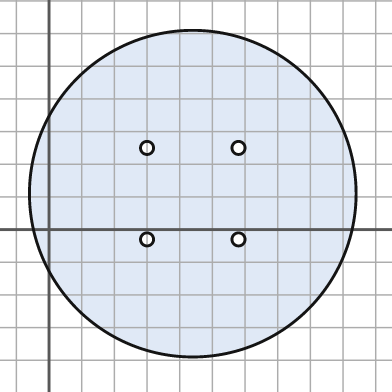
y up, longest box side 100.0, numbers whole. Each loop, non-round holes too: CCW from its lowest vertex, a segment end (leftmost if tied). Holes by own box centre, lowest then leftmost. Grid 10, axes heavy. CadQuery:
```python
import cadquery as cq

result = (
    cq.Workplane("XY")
    .moveTo(44.0, 11.0)
    .circle(50.0)
    .moveTo(30.0, -3.0)
    .circle(2.0)
    .moveTo(58.0, -3.0)
    .circle(2.0)
    .moveTo(30.0, 25.0)
    .circle(2.0)
    .moveTo(58.0, 25.0)
    .circle(2.0)
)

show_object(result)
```